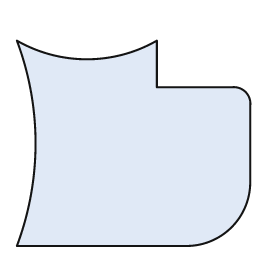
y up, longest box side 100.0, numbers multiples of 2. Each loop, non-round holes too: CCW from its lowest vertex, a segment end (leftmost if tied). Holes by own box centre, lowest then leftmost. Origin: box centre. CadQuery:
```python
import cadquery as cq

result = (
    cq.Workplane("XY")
    .moveTo(-50.0, -44.0)
    .lineTo(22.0, -44.0)
    .threePointArc((42.0, -36.0), (50.0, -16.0))
    .lineTo(50.0, 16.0)
    .threePointArc((48.0, 22.0), (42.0, 24.0))
    .lineTo(10.0, 24.0)
    .lineTo(10.0, 44.0)
    .threePointArc((-20.0, 36.0), (-50.0, 44.0))
    .threePointArc((-42.0, 0.0), (-50.0, -44.0))
    .close()
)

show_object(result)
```